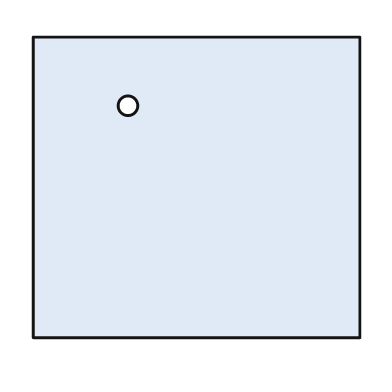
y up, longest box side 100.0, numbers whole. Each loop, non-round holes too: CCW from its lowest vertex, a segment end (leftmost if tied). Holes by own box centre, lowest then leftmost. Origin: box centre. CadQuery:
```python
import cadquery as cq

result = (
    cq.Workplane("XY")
    .moveTo(-50.0, -46.0)
    .lineTo(50.0, -46.0)
    .lineTo(50.0, 46.0)
    .lineTo(-50.0, 46.0)
    .close()
    .moveTo(-21.0, 25.0)
    .circle(3.0)
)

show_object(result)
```